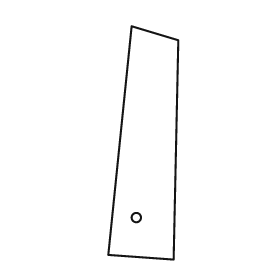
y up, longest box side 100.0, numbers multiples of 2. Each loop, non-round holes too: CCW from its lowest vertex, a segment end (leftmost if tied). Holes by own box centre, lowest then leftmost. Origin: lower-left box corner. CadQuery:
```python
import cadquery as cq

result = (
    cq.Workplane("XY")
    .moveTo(28.0, 0.0)
    .lineTo(30.0, 94.0)
    .lineTo(10.0, 100.0)
    .lineTo(0.0, 2.0)
    .close()
    .moveTo(12.0, 18.0)
    .circle(2.0)
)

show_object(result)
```